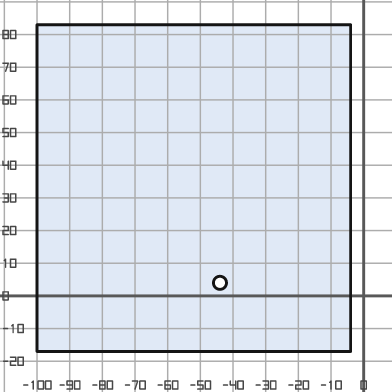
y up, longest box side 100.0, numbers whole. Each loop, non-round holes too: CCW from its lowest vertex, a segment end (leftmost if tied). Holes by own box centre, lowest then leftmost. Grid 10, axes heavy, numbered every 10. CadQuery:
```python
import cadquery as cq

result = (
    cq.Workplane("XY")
    .moveTo(-100.0, -17.0)
    .lineTo(-4.0, -17.0)
    .lineTo(-4.0, 83.0)
    .lineTo(-100.0, 83.0)
    .close()
    .moveTo(-44.0, 4.0)
    .circle(2.0)
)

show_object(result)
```